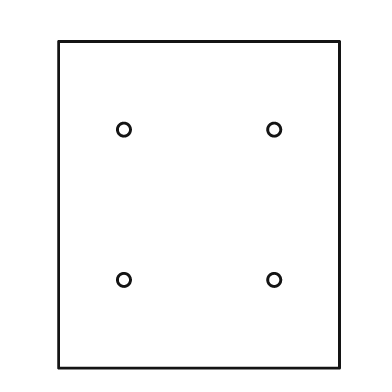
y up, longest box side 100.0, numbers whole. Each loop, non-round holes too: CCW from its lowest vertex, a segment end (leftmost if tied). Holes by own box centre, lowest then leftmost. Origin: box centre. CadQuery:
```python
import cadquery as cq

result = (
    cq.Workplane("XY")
    .moveTo(-43.0, -50.0)
    .lineTo(43.0, -50.0)
    .lineTo(43.0, 50.0)
    .lineTo(-43.0, 50.0)
    .close()
    .moveTo(-23.0, -23.0)
    .circle(2.0)
    .moveTo(23.0, -23.0)
    .circle(2.0)
    .moveTo(-23.0, 23.0)
    .circle(2.0)
    .moveTo(23.0, 23.0)
    .circle(2.0)
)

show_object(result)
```